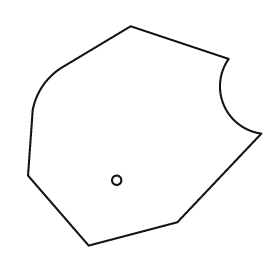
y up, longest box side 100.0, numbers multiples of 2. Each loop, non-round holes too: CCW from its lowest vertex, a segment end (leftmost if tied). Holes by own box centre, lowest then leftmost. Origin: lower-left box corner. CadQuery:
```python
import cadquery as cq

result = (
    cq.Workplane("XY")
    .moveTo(26.0, 0.0)
    .lineTo(64.0, 10.0)
    .lineTo(100.0, 48.0)
    .threePointArc((84.0, 60.0), (86.0, 80.0))
    .lineTo(44.0, 94.0)
    .lineTo(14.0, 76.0)
    .threePointArc((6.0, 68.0), (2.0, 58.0))
    .lineTo(0.0, 30.0)
    .close()
    .moveTo(38.0, 28.0)
    .circle(2.0)
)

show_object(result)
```